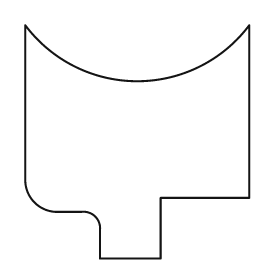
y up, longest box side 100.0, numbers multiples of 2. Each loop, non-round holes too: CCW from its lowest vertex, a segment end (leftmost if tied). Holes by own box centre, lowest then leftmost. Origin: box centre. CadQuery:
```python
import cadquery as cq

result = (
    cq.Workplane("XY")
    .moveTo(-16.0, -50.0)
    .lineTo(10.0, -50.0)
    .lineTo(10.0, -24.0)
    .lineTo(48.0, -24.0)
    .lineTo(48.0, 50.0)
    .threePointArc((0.0, 26.0), (-48.0, 50.0))
    .lineTo(-48.0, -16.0)
    .threePointArc((-44.0, -26.0), (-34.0, -30.0))
    .lineTo(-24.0, -30.0)
    .threePointArc((-18.0, -32.0), (-16.0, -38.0))
    .close()
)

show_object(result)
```